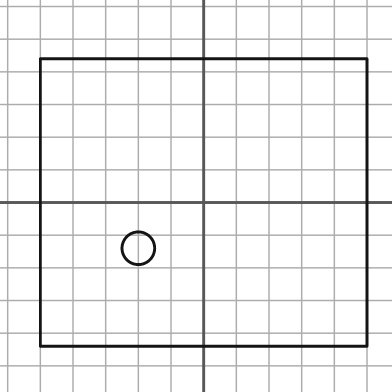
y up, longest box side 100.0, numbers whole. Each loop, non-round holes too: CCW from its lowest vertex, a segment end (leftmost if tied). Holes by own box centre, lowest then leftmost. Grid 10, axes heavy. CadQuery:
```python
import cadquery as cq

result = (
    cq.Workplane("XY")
    .moveTo(-50.0, -44.0)
    .lineTo(50.0, -44.0)
    .lineTo(50.0, 44.0)
    .lineTo(-50.0, 44.0)
    .close()
    .moveTo(-20.0, -14.0)
    .circle(5.0)
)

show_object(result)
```